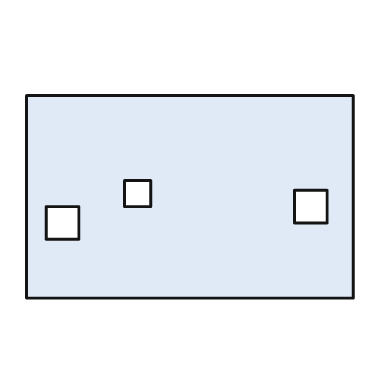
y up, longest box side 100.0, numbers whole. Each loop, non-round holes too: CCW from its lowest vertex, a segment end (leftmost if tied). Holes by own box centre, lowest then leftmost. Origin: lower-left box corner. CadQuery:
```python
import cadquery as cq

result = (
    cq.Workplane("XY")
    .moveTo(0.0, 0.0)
    .lineTo(100.0, 0.0)
    .lineTo(100.0, 62.0)
    .lineTo(0.0, 62.0)
    .close()
    .moveTo(6.0, 18.0)
    .lineTo(16.0, 18.0)
    .lineTo(16.0, 28.0)
    .lineTo(6.0, 28.0)
    .close()
    .moveTo(82.0, 23.0)
    .lineTo(92.0, 23.0)
    .lineTo(92.0, 33.0)
    .lineTo(82.0, 33.0)
    .close()
    .moveTo(30.0, 28.0)
    .lineTo(38.0, 28.0)
    .lineTo(38.0, 36.0)
    .lineTo(30.0, 36.0)
    .close()
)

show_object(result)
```